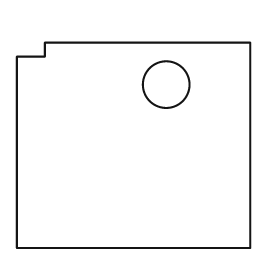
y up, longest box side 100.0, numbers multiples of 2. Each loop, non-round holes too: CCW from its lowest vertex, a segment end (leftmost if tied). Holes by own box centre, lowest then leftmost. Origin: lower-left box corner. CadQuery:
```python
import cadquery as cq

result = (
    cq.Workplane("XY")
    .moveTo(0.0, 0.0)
    .lineTo(100.0, 0.0)
    .lineTo(100.0, 88.0)
    .lineTo(12.0, 88.0)
    .lineTo(12.0, 82.0)
    .lineTo(0.0, 82.0)
    .close()
    .moveTo(64.0, 70.0)
    .circle(10.0)
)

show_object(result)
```